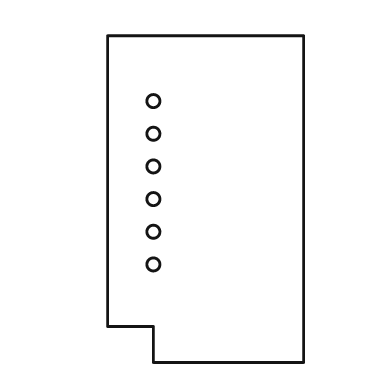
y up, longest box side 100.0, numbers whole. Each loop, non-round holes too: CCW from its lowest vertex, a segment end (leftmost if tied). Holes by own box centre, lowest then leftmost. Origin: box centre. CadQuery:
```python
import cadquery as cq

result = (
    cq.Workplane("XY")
    .moveTo(-16.0, -50.0)
    .lineTo(30.0, -50.0)
    .lineTo(30.0, 50.0)
    .lineTo(-30.0, 50.0)
    .lineTo(-30.0, -39.0)
    .lineTo(-16.0, -39.0)
    .close()
    .moveTo(-16.0, -20.0)
    .circle(2.0)
    .moveTo(-16.0, -10.0)
    .circle(2.0)
    .moveTo(-16.0, 0.0)
    .circle(2.0)
    .moveTo(-16.0, 10.0)
    .circle(2.0)
    .moveTo(-16.0, 20.0)
    .circle(2.0)
    .moveTo(-16.0, 30.0)
    .circle(2.0)
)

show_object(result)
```